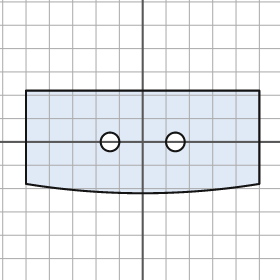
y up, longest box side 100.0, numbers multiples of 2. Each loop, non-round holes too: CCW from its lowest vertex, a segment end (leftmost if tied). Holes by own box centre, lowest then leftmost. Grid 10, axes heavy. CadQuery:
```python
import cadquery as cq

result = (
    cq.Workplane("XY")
    .moveTo(-50.0, -18.0)
    .threePointArc((0.0, -22.0), (50.0, -18.0))
    .lineTo(50.0, 22.0)
    .lineTo(-50.0, 22.0)
    .close()
    .moveTo(-14.0, 0.0)
    .circle(4.0)
    .moveTo(14.0, 0.0)
    .circle(4.0)
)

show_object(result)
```